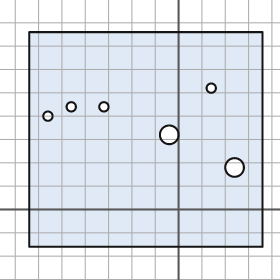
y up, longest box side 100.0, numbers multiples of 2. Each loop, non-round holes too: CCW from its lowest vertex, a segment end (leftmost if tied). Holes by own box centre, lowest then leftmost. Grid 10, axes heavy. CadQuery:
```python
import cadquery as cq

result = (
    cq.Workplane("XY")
    .moveTo(-64.0, -16.0)
    .lineTo(36.0, -16.0)
    .lineTo(36.0, 76.0)
    .lineTo(-64.0, 76.0)
    .close()
    .moveTo(24.0, 18.0)
    .circle(4.0)
    .moveTo(-4.0, 32.0)
    .circle(4.0)
    .moveTo(-56.0, 40.0)
    .circle(2.0)
    .moveTo(-46.0, 44.0)
    .circle(2.0)
    .moveTo(-32.0, 44.0)
    .circle(2.0)
    .moveTo(14.0, 52.0)
    .circle(2.0)
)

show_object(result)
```